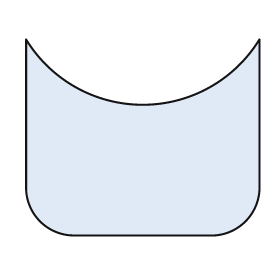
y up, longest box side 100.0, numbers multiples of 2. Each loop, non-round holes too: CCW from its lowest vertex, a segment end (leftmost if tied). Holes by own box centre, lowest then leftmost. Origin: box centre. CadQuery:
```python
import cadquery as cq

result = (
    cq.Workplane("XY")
    .moveTo(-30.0, -42.0)
    .lineTo(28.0, -42.0)
    .threePointArc((44.0, -36.0), (50.0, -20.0))
    .lineTo(50.0, 42.0)
    .threePointArc((0.0, 14.0), (-50.0, 42.0))
    .lineTo(-50.0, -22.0)
    .threePointArc((-44.0, -36.0), (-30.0, -42.0))
    .close()
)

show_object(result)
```